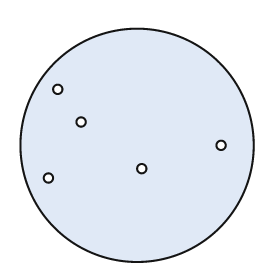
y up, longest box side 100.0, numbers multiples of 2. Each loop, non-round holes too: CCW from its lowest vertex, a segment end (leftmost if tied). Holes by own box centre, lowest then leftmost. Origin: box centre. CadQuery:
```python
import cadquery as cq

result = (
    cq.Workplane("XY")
    .moveTo(0.0, 0.0)
    .circle(50.0)
    .moveTo(-38.0, -14.0)
    .circle(2.0)
    .moveTo(2.0, -10.0)
    .circle(2.0)
    .moveTo(36.0, 0.0)
    .circle(2.0)
    .moveTo(-24.0, 10.0)
    .circle(2.0)
    .moveTo(-34.0, 24.0)
    .circle(2.0)
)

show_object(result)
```